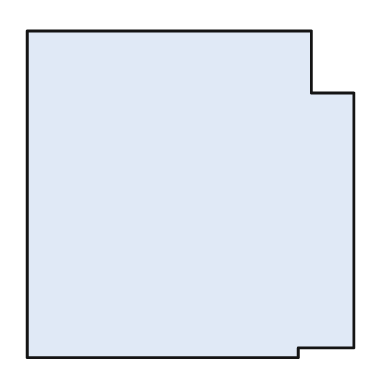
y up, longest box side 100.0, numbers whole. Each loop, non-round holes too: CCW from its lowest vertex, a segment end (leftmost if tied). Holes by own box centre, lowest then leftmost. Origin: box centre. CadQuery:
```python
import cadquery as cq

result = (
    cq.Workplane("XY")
    .moveTo(-50.0, -50.0)
    .lineTo(33.0, -50.0)
    .lineTo(33.0, -47.0)
    .lineTo(50.0, -47.0)
    .lineTo(50.0, 31.0)
    .lineTo(37.0, 31.0)
    .lineTo(37.0, 50.0)
    .lineTo(-50.0, 50.0)
    .close()
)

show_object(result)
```